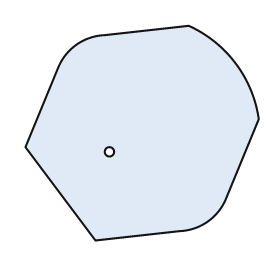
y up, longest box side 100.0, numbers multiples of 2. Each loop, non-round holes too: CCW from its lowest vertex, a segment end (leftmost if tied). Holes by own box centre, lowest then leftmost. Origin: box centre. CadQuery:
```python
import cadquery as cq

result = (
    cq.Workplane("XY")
    .moveTo(-20.0, -46.0)
    .lineTo(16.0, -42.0)
    .threePointArc((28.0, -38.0), (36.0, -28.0))
    .lineTo(50.0, 6.0)
    .threePointArc((40.0, 30.0), (20.0, 46.0))
    .lineTo(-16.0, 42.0)
    .threePointArc((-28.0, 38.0), (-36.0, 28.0))
    .lineTo(-50.0, -6.0)
    .close()
    .moveTo(-14.0, -8.0)
    .circle(2.0)
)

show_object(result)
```